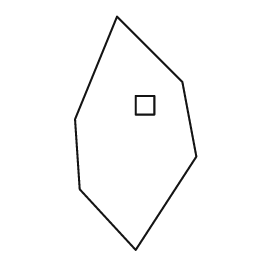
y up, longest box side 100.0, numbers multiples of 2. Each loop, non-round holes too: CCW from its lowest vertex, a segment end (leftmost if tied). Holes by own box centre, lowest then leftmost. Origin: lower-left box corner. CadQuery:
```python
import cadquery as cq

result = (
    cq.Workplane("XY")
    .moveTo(26.0, 0.0)
    .lineTo(52.0, 40.0)
    .lineTo(46.0, 72.0)
    .lineTo(18.0, 100.0)
    .lineTo(0.0, 56.0)
    .lineTo(2.0, 26.0)
    .close()
    .moveTo(26.0, 58.0)
    .lineTo(34.0, 58.0)
    .lineTo(34.0, 66.0)
    .lineTo(26.0, 66.0)
    .close()
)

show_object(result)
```